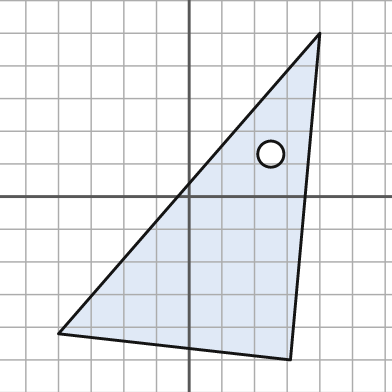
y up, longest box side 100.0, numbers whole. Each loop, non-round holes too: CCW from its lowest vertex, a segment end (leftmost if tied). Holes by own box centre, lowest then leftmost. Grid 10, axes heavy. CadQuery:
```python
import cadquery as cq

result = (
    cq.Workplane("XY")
    .moveTo(31.0, -50.0)
    .lineTo(40.0, 50.0)
    .lineTo(-40.0, -42.0)
    .close()
    .moveTo(25.0, 13.0)
    .circle(4.0)
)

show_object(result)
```